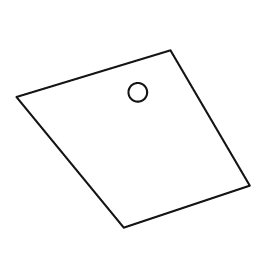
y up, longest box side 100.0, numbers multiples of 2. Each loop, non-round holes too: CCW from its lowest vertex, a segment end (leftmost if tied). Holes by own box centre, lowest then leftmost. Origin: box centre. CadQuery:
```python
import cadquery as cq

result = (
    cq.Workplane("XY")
    .moveTo(-4.0, -38.0)
    .lineTo(50.0, -20.0)
    .lineTo(16.0, 38.0)
    .lineTo(-50.0, 18.0)
    .close()
    .moveTo(2.0, 20.0)
    .circle(4.0)
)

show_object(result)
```